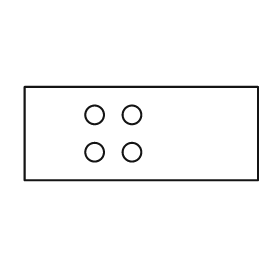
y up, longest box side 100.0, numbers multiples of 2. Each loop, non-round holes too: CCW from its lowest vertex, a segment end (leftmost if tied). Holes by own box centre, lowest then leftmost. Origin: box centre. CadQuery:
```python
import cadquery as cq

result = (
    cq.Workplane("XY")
    .moveTo(-50.0, -20.0)
    .lineTo(50.0, -20.0)
    .lineTo(50.0, 20.0)
    .lineTo(-50.0, 20.0)
    .close()
    .moveTo(-20.0, -8.0)
    .circle(4.0)
    .moveTo(-4.0, -8.0)
    .circle(4.0)
    .moveTo(-20.0, 8.0)
    .circle(4.0)
    .moveTo(-4.0, 8.0)
    .circle(4.0)
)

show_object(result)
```